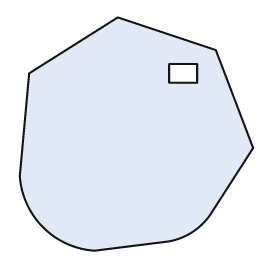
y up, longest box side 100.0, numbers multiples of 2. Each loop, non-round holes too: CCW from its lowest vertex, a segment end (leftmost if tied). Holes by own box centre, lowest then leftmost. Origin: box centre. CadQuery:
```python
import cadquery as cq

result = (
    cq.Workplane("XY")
    .moveTo(-18.0, -50.0)
    .lineTo(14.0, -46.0)
    .threePointArc((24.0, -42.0), (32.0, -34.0))
    .lineTo(50.0, -6.0)
    .lineTo(34.0, 36.0)
    .lineTo(-8.0, 50.0)
    .lineTo(-46.0, 26.0)
    .lineTo(-50.0, -18.0)
    .threePointArc((-40.0, -40.0), (-18.0, -50.0))
    .close()
    .moveTo(14.0, 22.0)
    .lineTo(26.0, 22.0)
    .lineTo(26.0, 30.0)
    .lineTo(14.0, 30.0)
    .close()
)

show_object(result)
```